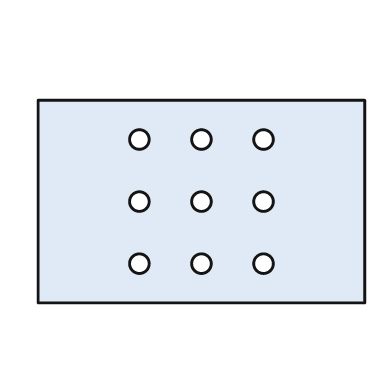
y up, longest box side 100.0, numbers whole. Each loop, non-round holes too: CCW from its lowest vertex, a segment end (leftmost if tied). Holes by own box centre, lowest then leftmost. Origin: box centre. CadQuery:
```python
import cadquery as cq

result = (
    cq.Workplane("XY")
    .moveTo(-50.0, -31.0)
    .lineTo(50.0, -31.0)
    .lineTo(50.0, 31.0)
    .lineTo(-50.0, 31.0)
    .close()
    .moveTo(-19.0, -19.0)
    .circle(3.0)
    .moveTo(0.0, -19.0)
    .circle(3.0)
    .moveTo(19.0, -19.0)
    .circle(3.0)
    .moveTo(-19.0, 0.0)
    .circle(3.0)
    .moveTo(0.0, 0.0)
    .circle(3.0)
    .moveTo(19.0, 0.0)
    .circle(3.0)
    .moveTo(-19.0, 19.0)
    .circle(3.0)
    .moveTo(0.0, 19.0)
    .circle(3.0)
    .moveTo(19.0, 19.0)
    .circle(3.0)
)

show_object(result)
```